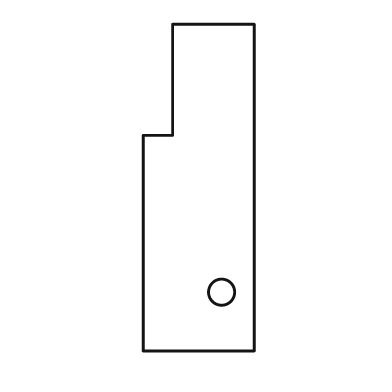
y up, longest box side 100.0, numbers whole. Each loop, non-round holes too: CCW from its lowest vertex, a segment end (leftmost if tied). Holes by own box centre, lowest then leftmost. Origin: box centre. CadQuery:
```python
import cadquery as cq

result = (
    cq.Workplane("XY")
    .moveTo(-17.0, -50.0)
    .lineTo(17.0, -50.0)
    .lineTo(17.0, 50.0)
    .lineTo(-8.0, 50.0)
    .lineTo(-8.0, 16.0)
    .lineTo(-17.0, 16.0)
    .close()
    .moveTo(7.0, -32.0)
    .circle(4.0)
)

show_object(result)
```